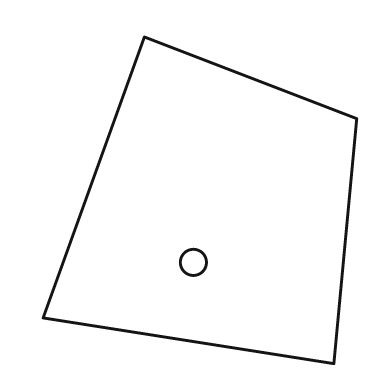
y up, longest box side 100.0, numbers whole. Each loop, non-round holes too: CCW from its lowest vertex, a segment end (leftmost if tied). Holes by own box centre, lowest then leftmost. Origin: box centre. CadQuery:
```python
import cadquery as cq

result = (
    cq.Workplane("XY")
    .moveTo(41.0, -50.0)
    .lineTo(48.0, 25.0)
    .lineTo(-17.0, 50.0)
    .lineTo(-48.0, -36.0)
    .close()
    .moveTo(-2.0, -19.0)
    .circle(4.0)
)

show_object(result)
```